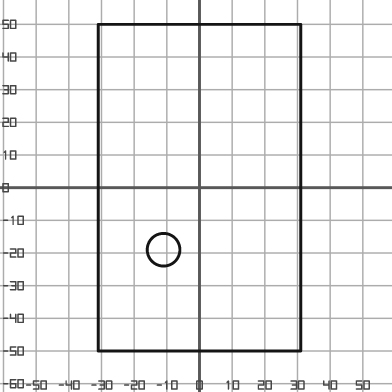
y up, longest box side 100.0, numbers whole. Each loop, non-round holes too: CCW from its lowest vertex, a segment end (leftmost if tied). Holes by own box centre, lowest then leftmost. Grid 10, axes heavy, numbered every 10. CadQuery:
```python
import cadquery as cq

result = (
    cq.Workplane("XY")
    .moveTo(-31.0, -50.0)
    .lineTo(31.0, -50.0)
    .lineTo(31.0, 50.0)
    .lineTo(-31.0, 50.0)
    .close()
    .moveTo(-11.0, -19.0)
    .circle(5.0)
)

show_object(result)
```